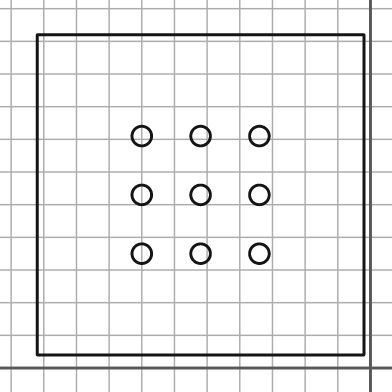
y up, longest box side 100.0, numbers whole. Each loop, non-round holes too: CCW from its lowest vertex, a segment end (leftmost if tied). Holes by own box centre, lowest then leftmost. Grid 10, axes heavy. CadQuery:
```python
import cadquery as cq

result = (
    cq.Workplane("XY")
    .moveTo(-102.0, 4.0)
    .lineTo(-2.0, 4.0)
    .lineTo(-2.0, 102.0)
    .lineTo(-102.0, 102.0)
    .close()
    .moveTo(-70.0, 35.0)
    .circle(3.0)
    .moveTo(-52.0, 35.0)
    .circle(3.0)
    .moveTo(-34.0, 35.0)
    .circle(3.0)
    .moveTo(-70.0, 53.0)
    .circle(3.0)
    .moveTo(-52.0, 53.0)
    .circle(3.0)
    .moveTo(-34.0, 53.0)
    .circle(3.0)
    .moveTo(-70.0, 71.0)
    .circle(3.0)
    .moveTo(-52.0, 71.0)
    .circle(3.0)
    .moveTo(-34.0, 71.0)
    .circle(3.0)
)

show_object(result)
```